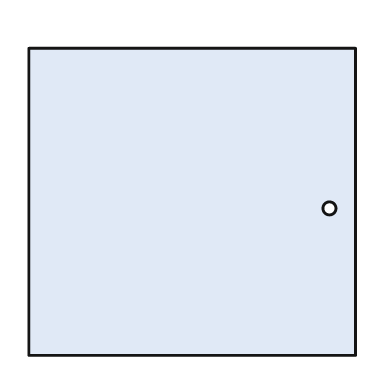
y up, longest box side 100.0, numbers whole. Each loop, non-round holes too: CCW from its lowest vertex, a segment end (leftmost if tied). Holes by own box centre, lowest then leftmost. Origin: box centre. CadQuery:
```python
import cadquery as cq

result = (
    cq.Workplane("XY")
    .moveTo(-50.0, -47.0)
    .lineTo(50.0, -47.0)
    .lineTo(50.0, 47.0)
    .lineTo(-50.0, 47.0)
    .close()
    .moveTo(42.0, -2.0)
    .circle(2.0)
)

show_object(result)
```